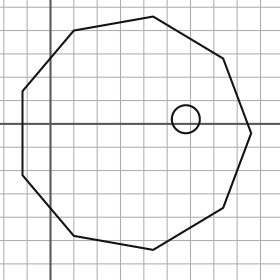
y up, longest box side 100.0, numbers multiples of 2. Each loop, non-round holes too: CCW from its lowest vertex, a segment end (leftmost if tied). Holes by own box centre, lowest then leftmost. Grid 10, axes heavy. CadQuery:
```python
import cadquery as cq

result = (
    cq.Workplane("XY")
    .moveTo(44.0, -54.0)
    .lineTo(74.0, -36.0)
    .lineTo(86.0, -4.0)
    .lineTo(74.0, 28.0)
    .lineTo(44.0, 46.0)
    .lineTo(10.0, 40.0)
    .lineTo(-12.0, 14.0)
    .lineTo(-12.0, -22.0)
    .lineTo(10.0, -48.0)
    .close()
    .moveTo(58.0, 2.0)
    .circle(6.0)
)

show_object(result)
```